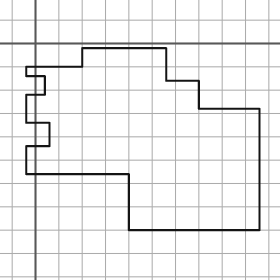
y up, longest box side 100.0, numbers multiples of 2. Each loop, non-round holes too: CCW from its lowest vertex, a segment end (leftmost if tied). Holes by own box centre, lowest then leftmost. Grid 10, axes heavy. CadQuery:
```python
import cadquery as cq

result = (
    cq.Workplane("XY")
    .moveTo(40.0, -80.0)
    .lineTo(96.0, -80.0)
    .lineTo(96.0, -28.0)
    .lineTo(70.0, -28.0)
    .lineTo(70.0, -16.0)
    .lineTo(56.0, -16.0)
    .lineTo(56.0, -2.0)
    .lineTo(20.0, -2.0)
    .lineTo(20.0, -10.0)
    .lineTo(-4.0, -10.0)
    .lineTo(-4.0, -14.0)
    .lineTo(4.0, -14.0)
    .lineTo(4.0, -22.0)
    .lineTo(-4.0, -22.0)
    .lineTo(-4.0, -34.0)
    .lineTo(6.0, -34.0)
    .lineTo(6.0, -44.0)
    .lineTo(-4.0, -44.0)
    .lineTo(-4.0, -56.0)
    .lineTo(40.0, -56.0)
    .close()
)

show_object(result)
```